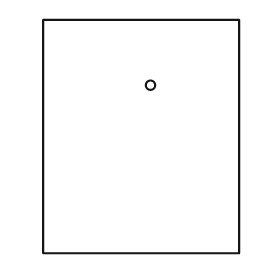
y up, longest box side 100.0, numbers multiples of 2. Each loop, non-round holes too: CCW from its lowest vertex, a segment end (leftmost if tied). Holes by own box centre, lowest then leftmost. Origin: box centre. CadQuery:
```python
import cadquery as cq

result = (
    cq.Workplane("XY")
    .moveTo(-42.0, -50.0)
    .lineTo(42.0, -50.0)
    .lineTo(42.0, 50.0)
    .lineTo(-42.0, 50.0)
    .close()
    .moveTo(4.0, 22.0)
    .circle(2.0)
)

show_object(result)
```